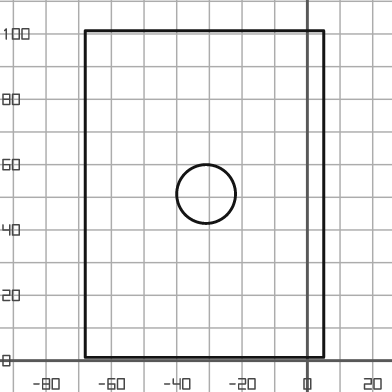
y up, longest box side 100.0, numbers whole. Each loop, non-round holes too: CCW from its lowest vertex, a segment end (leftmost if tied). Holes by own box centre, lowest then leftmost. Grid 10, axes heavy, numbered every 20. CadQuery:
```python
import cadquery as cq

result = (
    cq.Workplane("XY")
    .moveTo(-68.0, 1.0)
    .lineTo(5.0, 1.0)
    .lineTo(5.0, 101.0)
    .lineTo(-68.0, 101.0)
    .close()
    .moveTo(-31.0, 51.0)
    .circle(9.0)
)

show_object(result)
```